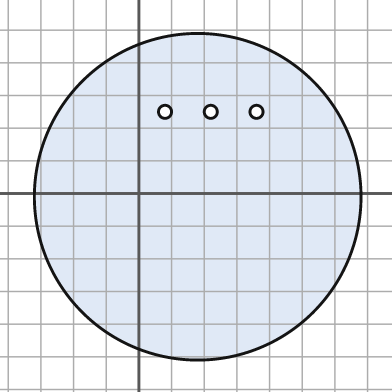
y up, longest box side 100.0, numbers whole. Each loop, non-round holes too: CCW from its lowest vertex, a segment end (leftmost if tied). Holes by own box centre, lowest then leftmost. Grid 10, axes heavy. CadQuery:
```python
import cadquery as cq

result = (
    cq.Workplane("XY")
    .moveTo(18.0, -1.0)
    .circle(50.0)
    .moveTo(8.0, 25.0)
    .circle(2.0)
    .moveTo(22.0, 25.0)
    .circle(2.0)
    .moveTo(36.0, 25.0)
    .circle(2.0)
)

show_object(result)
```